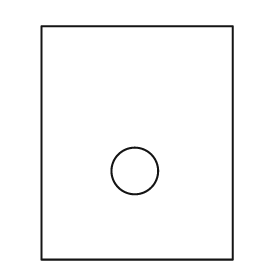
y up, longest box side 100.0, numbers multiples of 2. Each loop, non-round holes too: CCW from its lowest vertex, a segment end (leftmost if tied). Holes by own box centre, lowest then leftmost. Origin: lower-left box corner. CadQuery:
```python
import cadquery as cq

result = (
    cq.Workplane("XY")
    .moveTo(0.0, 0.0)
    .lineTo(82.0, 0.0)
    .lineTo(82.0, 100.0)
    .lineTo(0.0, 100.0)
    .close()
    .moveTo(40.0, 38.0)
    .circle(10.0)
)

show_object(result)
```